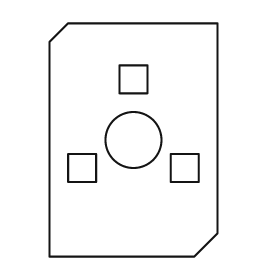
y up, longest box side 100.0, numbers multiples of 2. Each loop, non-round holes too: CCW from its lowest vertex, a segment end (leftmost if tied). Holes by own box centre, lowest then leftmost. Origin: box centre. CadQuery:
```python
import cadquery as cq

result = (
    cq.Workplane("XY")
    .moveTo(-36.0, -50.0)
    .lineTo(26.0, -50.0)
    .lineTo(36.0, -40.0)
    .lineTo(36.0, 50.0)
    .lineTo(-28.0, 50.0)
    .lineTo(-36.0, 42.0)
    .close()
    .moveTo(-28.0, -18.0)
    .lineTo(-16.0, -18.0)
    .lineTo(-16.0, -6.0)
    .lineTo(-28.0, -6.0)
    .close()
    .moveTo(16.0, -18.0)
    .lineTo(28.0, -18.0)
    .lineTo(28.0, -6.0)
    .lineTo(16.0, -6.0)
    .close()
    .moveTo(0.0, 0.0)
    .circle(12.0)
    .moveTo(-6.0, 20.0)
    .lineTo(6.0, 20.0)
    .lineTo(6.0, 32.0)
    .lineTo(-6.0, 32.0)
    .close()
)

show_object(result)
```